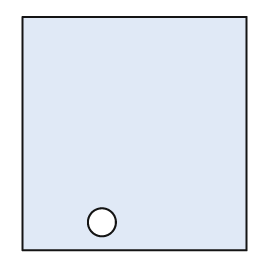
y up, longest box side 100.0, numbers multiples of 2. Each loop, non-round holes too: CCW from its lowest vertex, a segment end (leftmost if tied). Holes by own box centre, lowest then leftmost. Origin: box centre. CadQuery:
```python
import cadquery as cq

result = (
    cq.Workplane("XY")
    .moveTo(-48.0, -50.0)
    .lineTo(48.0, -50.0)
    .lineTo(48.0, 50.0)
    .lineTo(-48.0, 50.0)
    .close()
    .moveTo(-14.0, -38.0)
    .circle(6.0)
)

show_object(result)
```